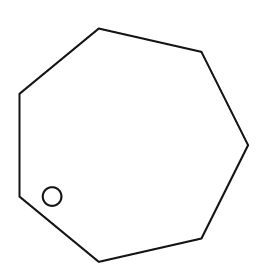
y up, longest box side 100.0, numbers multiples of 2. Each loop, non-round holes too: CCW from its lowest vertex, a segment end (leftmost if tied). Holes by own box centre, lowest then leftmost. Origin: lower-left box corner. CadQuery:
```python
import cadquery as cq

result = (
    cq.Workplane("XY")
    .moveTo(34.0, 0.0)
    .lineTo(78.0, 10.0)
    .lineTo(98.0, 50.0)
    .lineTo(78.0, 90.0)
    .lineTo(34.0, 100.0)
    .lineTo(0.0, 72.0)
    .lineTo(0.0, 28.0)
    .close()
    .moveTo(14.0, 28.0)
    .circle(4.0)
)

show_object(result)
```